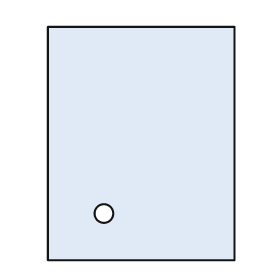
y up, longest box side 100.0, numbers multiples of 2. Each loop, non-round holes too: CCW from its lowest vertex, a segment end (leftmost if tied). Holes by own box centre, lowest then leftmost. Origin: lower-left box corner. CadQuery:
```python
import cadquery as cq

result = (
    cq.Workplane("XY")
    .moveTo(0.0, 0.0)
    .lineTo(80.0, 0.0)
    .lineTo(80.0, 100.0)
    .lineTo(0.0, 100.0)
    .close()
    .moveTo(24.0, 20.0)
    .circle(4.0)
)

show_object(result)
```